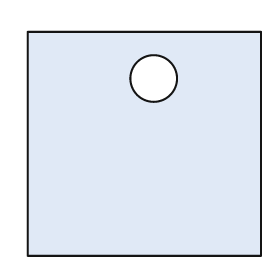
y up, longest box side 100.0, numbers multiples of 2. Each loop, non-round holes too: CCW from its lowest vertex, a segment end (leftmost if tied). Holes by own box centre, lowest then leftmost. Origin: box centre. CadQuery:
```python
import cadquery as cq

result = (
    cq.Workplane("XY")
    .moveTo(-50.0, -48.0)
    .lineTo(50.0, -48.0)
    .lineTo(50.0, 48.0)
    .lineTo(-50.0, 48.0)
    .close()
    .moveTo(4.0, 28.0)
    .circle(10.0)
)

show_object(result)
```